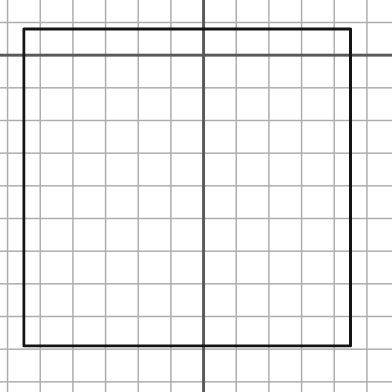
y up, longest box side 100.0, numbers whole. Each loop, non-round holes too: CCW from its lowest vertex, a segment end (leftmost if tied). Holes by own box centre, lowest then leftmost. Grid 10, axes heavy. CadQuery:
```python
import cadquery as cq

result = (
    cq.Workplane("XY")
    .moveTo(-55.0, -89.0)
    .lineTo(45.0, -89.0)
    .lineTo(45.0, 8.0)
    .lineTo(-55.0, 8.0)
    .close()
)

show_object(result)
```